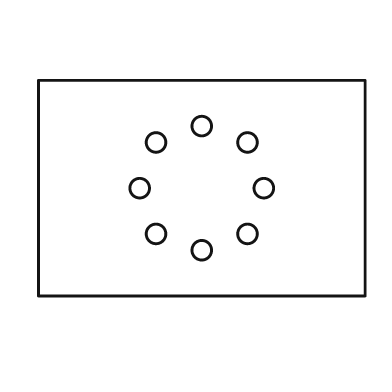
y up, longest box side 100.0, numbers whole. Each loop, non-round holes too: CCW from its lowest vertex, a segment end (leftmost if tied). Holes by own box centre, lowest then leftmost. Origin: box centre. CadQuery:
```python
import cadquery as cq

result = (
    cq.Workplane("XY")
    .moveTo(-50.0, -33.0)
    .lineTo(50.0, -33.0)
    .lineTo(50.0, 33.0)
    .lineTo(-50.0, 33.0)
    .close()
    .moveTo(0.0, -19.0)
    .circle(3.0)
    .moveTo(-14.0, -14.0)
    .circle(3.0)
    .moveTo(14.0, -14.0)
    .circle(3.0)
    .moveTo(-19.0, 0.0)
    .circle(3.0)
    .moveTo(19.0, 0.0)
    .circle(3.0)
    .moveTo(-14.0, 14.0)
    .circle(3.0)
    .moveTo(14.0, 14.0)
    .circle(3.0)
    .moveTo(0.0, 19.0)
    .circle(3.0)
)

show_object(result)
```